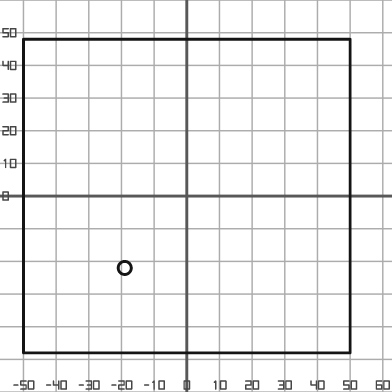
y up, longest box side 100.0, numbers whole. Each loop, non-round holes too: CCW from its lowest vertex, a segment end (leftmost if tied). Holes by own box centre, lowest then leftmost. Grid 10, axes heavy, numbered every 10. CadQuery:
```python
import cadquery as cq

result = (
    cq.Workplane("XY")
    .moveTo(-50.0, -48.0)
    .lineTo(50.0, -48.0)
    .lineTo(50.0, 48.0)
    .lineTo(-50.0, 48.0)
    .close()
    .moveTo(-19.0, -22.0)
    .circle(2.0)
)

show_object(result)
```